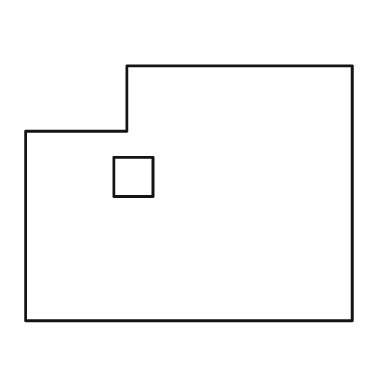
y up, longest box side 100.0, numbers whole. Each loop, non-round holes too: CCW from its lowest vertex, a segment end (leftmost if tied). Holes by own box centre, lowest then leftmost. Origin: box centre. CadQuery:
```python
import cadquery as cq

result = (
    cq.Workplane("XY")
    .moveTo(-50.0, -39.0)
    .lineTo(50.0, -39.0)
    .lineTo(50.0, 39.0)
    .lineTo(-19.0, 39.0)
    .lineTo(-19.0, 19.0)
    .lineTo(-50.0, 19.0)
    .close()
    .moveTo(-23.0, -1.0)
    .lineTo(-11.0, -1.0)
    .lineTo(-11.0, 11.0)
    .lineTo(-23.0, 11.0)
    .close()
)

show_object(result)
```